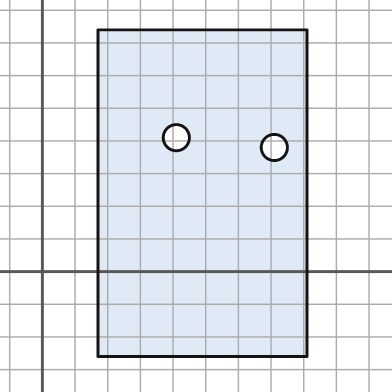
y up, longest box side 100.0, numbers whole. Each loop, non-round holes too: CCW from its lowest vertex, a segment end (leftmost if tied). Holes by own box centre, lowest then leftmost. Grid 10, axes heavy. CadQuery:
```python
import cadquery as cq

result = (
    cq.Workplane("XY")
    .moveTo(17.0, -26.0)
    .lineTo(81.0, -26.0)
    .lineTo(81.0, 74.0)
    .lineTo(17.0, 74.0)
    .close()
    .moveTo(71.0, 38.0)
    .circle(4.0)
    .moveTo(41.0, 41.0)
    .circle(4.0)
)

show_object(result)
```